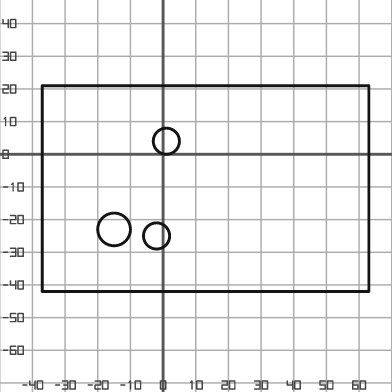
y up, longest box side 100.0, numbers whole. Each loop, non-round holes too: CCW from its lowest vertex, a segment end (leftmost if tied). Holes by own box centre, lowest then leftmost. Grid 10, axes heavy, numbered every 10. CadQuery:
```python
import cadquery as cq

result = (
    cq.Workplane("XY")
    .moveTo(-37.0, -42.0)
    .lineTo(63.0, -42.0)
    .lineTo(63.0, 21.0)
    .lineTo(-37.0, 21.0)
    .close()
    .moveTo(-2.0, -25.0)
    .circle(4.0)
    .moveTo(-15.0, -23.0)
    .circle(5.0)
    .moveTo(1.0, 4.0)
    .circle(4.0)
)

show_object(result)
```